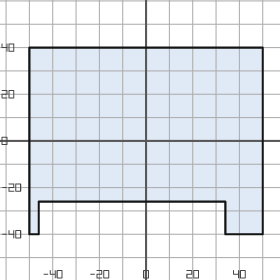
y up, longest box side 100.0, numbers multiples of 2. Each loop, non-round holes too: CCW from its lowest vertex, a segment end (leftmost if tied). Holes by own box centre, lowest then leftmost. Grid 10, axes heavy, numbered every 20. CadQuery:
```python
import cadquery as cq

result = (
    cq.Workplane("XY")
    .moveTo(-50.0, -40.0)
    .lineTo(-46.0, -40.0)
    .lineTo(-46.0, -26.0)
    .lineTo(34.0, -26.0)
    .lineTo(34.0, -40.0)
    .lineTo(50.0, -40.0)
    .lineTo(50.0, 40.0)
    .lineTo(-50.0, 40.0)
    .close()
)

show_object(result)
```